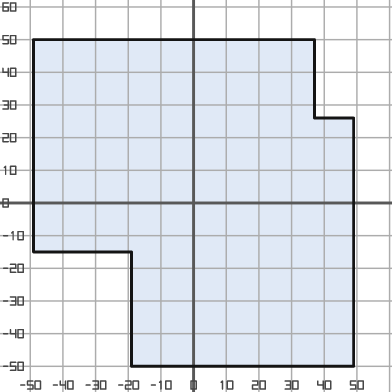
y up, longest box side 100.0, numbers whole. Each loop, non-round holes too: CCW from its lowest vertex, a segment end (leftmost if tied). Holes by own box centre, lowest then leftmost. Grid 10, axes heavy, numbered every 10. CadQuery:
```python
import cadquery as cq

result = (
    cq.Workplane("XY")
    .moveTo(-19.0, -50.0)
    .lineTo(49.0, -50.0)
    .lineTo(49.0, 26.0)
    .lineTo(37.0, 26.0)
    .lineTo(37.0, 50.0)
    .lineTo(-49.0, 50.0)
    .lineTo(-49.0, -15.0)
    .lineTo(-19.0, -15.0)
    .close()
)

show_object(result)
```